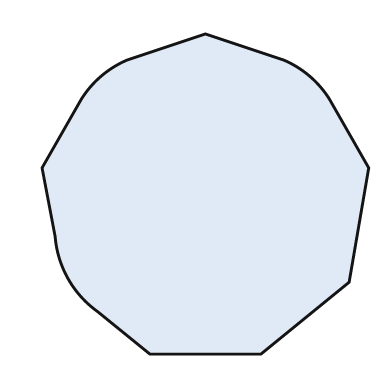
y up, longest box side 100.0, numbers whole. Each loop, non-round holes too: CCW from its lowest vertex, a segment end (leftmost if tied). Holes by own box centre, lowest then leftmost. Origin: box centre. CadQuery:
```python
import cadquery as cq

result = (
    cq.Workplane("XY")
    .moveTo(-17.0, -49.0)
    .lineTo(17.0, -49.0)
    .lineTo(44.0, -27.0)
    .lineTo(50.0, 8.0)
    .lineTo(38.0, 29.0)
    .threePointArc((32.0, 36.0), (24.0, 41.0))
    .lineTo(0.0, 49.0)
    .lineTo(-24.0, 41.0)
    .threePointArc((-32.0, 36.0), (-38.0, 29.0))
    .lineTo(-50.0, 8.0)
    .lineTo(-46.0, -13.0)
    .threePointArc((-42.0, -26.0), (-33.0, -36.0))
    .close()
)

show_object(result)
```